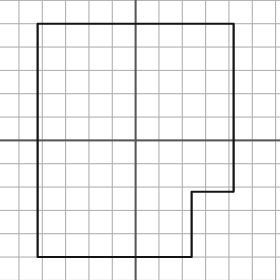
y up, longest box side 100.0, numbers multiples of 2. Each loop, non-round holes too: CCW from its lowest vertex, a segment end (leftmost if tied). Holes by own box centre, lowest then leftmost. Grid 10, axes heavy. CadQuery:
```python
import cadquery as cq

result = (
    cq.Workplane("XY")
    .moveTo(-42.0, -50.0)
    .lineTo(24.0, -50.0)
    .lineTo(24.0, -22.0)
    .lineTo(42.0, -22.0)
    .lineTo(42.0, 50.0)
    .lineTo(-42.0, 50.0)
    .close()
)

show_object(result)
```